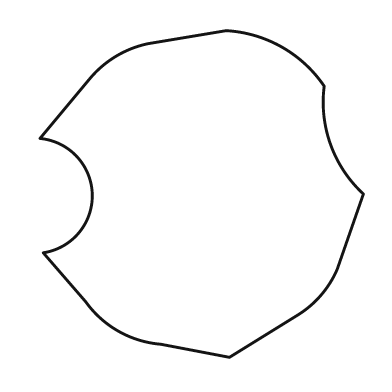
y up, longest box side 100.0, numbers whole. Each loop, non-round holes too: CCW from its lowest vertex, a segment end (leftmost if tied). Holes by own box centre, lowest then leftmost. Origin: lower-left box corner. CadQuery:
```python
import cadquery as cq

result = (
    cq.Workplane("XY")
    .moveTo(58.0, 0.0)
    .lineTo(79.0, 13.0)
    .threePointArc((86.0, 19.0), (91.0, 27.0))
    .lineTo(99.0, 50.0)
    .threePointArc((89.0, 65.0), (87.0, 83.0))
    .threePointArc((74.0, 95.0), (57.0, 100.0))
    .lineTo(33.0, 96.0)
    .threePointArc((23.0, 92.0), (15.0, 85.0))
    .lineTo(0.0, 67.0)
    .threePointArc((16.0, 50.0), (1.0, 32.0))
    .lineTo(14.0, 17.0)
    .threePointArc((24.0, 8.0), (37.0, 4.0))
    .close()
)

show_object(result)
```